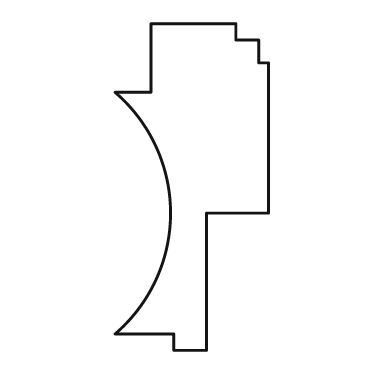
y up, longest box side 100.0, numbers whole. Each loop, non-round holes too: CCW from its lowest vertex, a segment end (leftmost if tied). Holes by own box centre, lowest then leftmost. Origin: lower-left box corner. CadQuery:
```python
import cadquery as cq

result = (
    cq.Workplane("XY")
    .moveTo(18.0, 0.0)
    .lineTo(28.0, 0.0)
    .lineTo(28.0, 42.0)
    .lineTo(47.0, 42.0)
    .lineTo(47.0, 88.0)
    .lineTo(44.0, 88.0)
    .lineTo(44.0, 95.0)
    .lineTo(37.0, 95.0)
    .lineTo(37.0, 100.0)
    .lineTo(11.0, 100.0)
    .lineTo(11.0, 79.0)
    .lineTo(0.0, 79.0)
    .threePointArc((17.0, 42.0), (0.0, 5.0))
    .lineTo(18.0, 5.0)
    .close()
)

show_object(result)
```